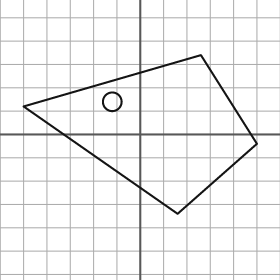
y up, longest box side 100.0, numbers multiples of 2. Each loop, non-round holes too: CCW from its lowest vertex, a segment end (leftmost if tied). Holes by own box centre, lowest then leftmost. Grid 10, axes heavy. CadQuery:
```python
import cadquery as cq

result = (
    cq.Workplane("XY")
    .moveTo(16.0, -34.0)
    .lineTo(50.0, -4.0)
    .lineTo(26.0, 34.0)
    .lineTo(-50.0, 12.0)
    .close()
    .moveTo(-12.0, 14.0)
    .circle(4.0)
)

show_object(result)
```